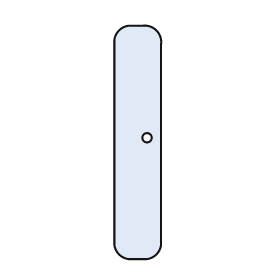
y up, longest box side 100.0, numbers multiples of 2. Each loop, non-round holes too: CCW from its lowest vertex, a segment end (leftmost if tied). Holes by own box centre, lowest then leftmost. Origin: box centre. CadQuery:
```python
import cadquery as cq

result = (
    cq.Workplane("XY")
    .moveTo(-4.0, -50.0)
    .lineTo(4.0, -50.0)
    .threePointArc((8.0, -48.0), (10.0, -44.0))
    .lineTo(10.0, 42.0)
    .threePointArc((8.0, 48.0), (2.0, 50.0))
    .lineTo(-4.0, 50.0)
    .threePointArc((-8.0, 48.0), (-10.0, 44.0))
    .lineTo(-10.0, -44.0)
    .threePointArc((-8.0, -48.0), (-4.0, -50.0))
    .close()
    .moveTo(4.0, 2.0)
    .circle(2.0)
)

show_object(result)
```